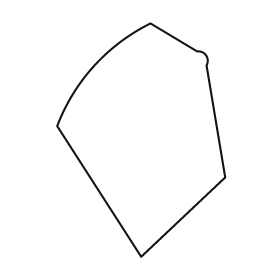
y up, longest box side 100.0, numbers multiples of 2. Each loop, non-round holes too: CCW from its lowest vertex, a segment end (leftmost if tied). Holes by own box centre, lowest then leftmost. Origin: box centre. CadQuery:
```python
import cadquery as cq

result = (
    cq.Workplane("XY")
    .moveTo(0.0, -50.0)
    .lineTo(36.0, -16.0)
    .lineTo(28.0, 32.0)
    .threePointArc((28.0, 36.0), (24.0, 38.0))
    .lineTo(4.0, 50.0)
    .threePointArc((-20.0, 32.0), (-36.0, 6.0))
    .close()
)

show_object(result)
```